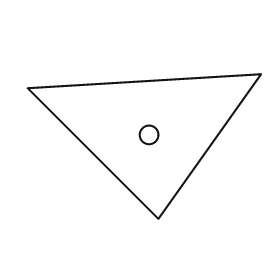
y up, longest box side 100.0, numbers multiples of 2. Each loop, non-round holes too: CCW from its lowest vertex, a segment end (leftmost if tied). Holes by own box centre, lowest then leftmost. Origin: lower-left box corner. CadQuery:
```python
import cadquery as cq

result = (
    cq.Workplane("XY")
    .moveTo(56.0, 0.0)
    .lineTo(100.0, 62.0)
    .lineTo(0.0, 56.0)
    .close()
    .moveTo(52.0, 36.0)
    .circle(4.0)
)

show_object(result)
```